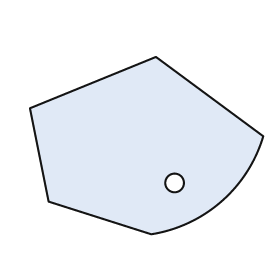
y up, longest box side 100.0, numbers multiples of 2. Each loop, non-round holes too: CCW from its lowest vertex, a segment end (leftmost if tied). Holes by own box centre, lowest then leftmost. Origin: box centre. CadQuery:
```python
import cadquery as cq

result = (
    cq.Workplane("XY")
    .moveTo(2.0, -38.0)
    .threePointArc((32.0, -24.0), (50.0, 4.0))
    .lineTo(4.0, 38.0)
    .lineTo(-50.0, 16.0)
    .lineTo(-42.0, -24.0)
    .close()
    .moveTo(12.0, -16.0)
    .circle(4.0)
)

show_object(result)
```